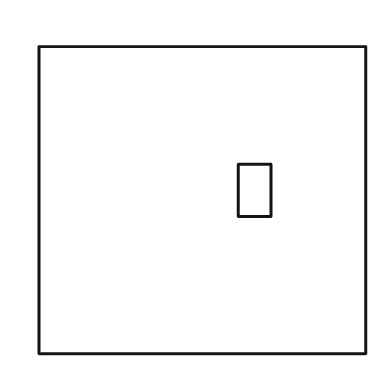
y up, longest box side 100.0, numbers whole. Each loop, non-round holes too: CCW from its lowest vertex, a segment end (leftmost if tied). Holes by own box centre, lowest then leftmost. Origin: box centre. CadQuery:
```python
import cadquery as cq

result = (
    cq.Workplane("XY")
    .moveTo(-50.0, -47.0)
    .lineTo(50.0, -47.0)
    .lineTo(50.0, 47.0)
    .lineTo(-50.0, 47.0)
    .close()
    .moveTo(11.0, -5.0)
    .lineTo(21.0, -5.0)
    .lineTo(21.0, 11.0)
    .lineTo(11.0, 11.0)
    .close()
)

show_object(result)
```